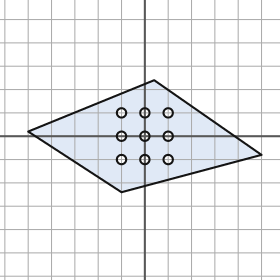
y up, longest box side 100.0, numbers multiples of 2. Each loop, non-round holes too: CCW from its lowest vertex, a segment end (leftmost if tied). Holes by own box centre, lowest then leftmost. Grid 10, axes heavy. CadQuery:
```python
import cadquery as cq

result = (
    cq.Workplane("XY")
    .moveTo(-10.0, -24.0)
    .lineTo(50.0, -8.0)
    .lineTo(4.0, 24.0)
    .lineTo(-50.0, 2.0)
    .close()
    .moveTo(-10.0, -10.0)
    .circle(2.0)
    .moveTo(0.0, -10.0)
    .circle(2.0)
    .moveTo(10.0, -10.0)
    .circle(2.0)
    .moveTo(-10.0, 0.0)
    .circle(2.0)
    .moveTo(0.0, 0.0)
    .circle(2.0)
    .moveTo(10.0, 0.0)
    .circle(2.0)
    .moveTo(-10.0, 10.0)
    .circle(2.0)
    .moveTo(0.0, 10.0)
    .circle(2.0)
    .moveTo(10.0, 10.0)
    .circle(2.0)
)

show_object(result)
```